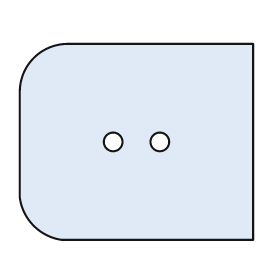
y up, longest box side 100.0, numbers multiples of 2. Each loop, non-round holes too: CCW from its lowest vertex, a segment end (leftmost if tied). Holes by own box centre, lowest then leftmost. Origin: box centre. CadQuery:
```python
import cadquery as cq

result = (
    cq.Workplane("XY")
    .moveTo(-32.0, -42.0)
    .lineTo(50.0, -42.0)
    .lineTo(50.0, 42.0)
    .lineTo(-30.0, 42.0)
    .threePointArc((-44.0, 36.0), (-50.0, 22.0))
    .lineTo(-50.0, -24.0)
    .threePointArc((-44.0, -36.0), (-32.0, -42.0))
    .close()
    .moveTo(-10.0, 0.0)
    .circle(4.0)
    .moveTo(10.0, 0.0)
    .circle(4.0)
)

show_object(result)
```